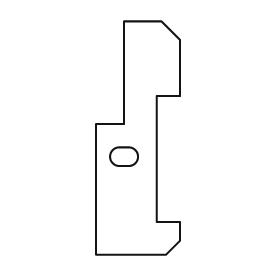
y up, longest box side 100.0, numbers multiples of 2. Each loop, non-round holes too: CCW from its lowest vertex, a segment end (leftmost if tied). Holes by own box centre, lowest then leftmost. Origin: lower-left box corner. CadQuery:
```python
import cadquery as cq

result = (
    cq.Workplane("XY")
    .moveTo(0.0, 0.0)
    .lineTo(30.0, 0.0)
    .lineTo(36.0, 6.0)
    .lineTo(36.0, 14.0)
    .lineTo(26.0, 14.0)
    .lineTo(26.0, 68.0)
    .lineTo(36.0, 68.0)
    .lineTo(36.0, 92.0)
    .lineTo(28.0, 100.0)
    .lineTo(12.0, 100.0)
    .lineTo(12.0, 56.0)
    .lineTo(0.0, 56.0)
    .close()
    .moveTo(10.0, 38.0)
    .lineTo(14.0, 38.0)
    .threePointArc((18.0, 42.0), (14.0, 46.0))
    .lineTo(10.0, 46.0)
    .threePointArc((6.0, 42.0), (10.0, 38.0))
    .close()
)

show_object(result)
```